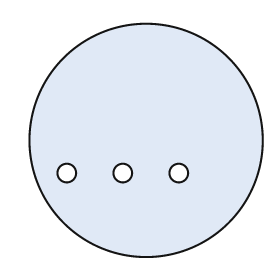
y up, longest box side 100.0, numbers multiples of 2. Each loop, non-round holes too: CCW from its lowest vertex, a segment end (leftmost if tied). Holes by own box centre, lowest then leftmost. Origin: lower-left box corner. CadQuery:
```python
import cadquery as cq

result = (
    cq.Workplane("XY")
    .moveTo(50.0, 50.0)
    .circle(50.0)
    .moveTo(16.0, 36.0)
    .circle(4.0)
    .moveTo(40.0, 36.0)
    .circle(4.0)
    .moveTo(64.0, 36.0)
    .circle(4.0)
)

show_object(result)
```